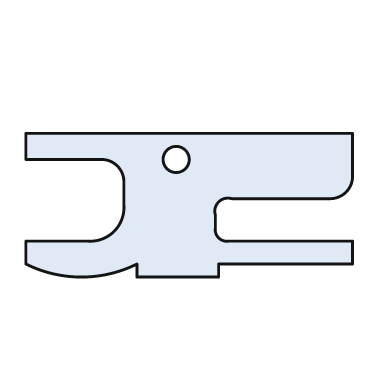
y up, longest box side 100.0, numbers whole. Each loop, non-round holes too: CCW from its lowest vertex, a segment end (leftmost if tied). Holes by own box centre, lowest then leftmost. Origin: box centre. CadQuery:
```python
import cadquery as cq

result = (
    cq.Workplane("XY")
    .moveTo(-16.0, -22.0)
    .lineTo(9.0, -22.0)
    .lineTo(9.0, -18.0)
    .lineTo(50.0, -18.0)
    .lineTo(50.0, -11.0)
    .lineTo(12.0, -11.0)
    .threePointArc((9.0, -10.0), (8.0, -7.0))
    .lineTo(8.0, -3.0)
    .threePointArc((9.0, 1.0), (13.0, 2.0))
    .lineTo(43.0, 2.0)
    .threePointArc((48.0, 4.0), (50.0, 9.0))
    .lineTo(50.0, 22.0)
    .lineTo(-50.0, 22.0)
    .lineTo(-50.0, 14.0)
    .lineTo(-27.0, 14.0)
    .threePointArc((-22.0, 12.0), (-20.0, 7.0))
    .lineTo(-20.0, 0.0)
    .threePointArc((-23.0, -8.0), (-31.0, -11.0))
    .lineTo(-50.0, -11.0)
    .lineTo(-50.0, -18.0)
    .threePointArc((-33.0, -22.0), (-16.0, -18.0))
    .close()
    .moveTo(-4.0, 14.0)
    .circle(4.0)
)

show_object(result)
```